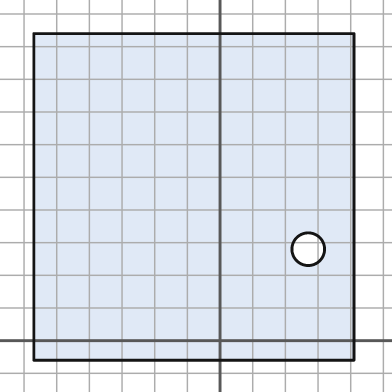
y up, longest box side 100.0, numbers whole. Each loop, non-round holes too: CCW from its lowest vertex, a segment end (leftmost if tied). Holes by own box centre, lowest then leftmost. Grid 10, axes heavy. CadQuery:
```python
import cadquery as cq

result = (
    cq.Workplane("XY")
    .moveTo(-57.0, -6.0)
    .lineTo(41.0, -6.0)
    .lineTo(41.0, 94.0)
    .lineTo(-57.0, 94.0)
    .close()
    .moveTo(27.0, 28.0)
    .circle(5.0)
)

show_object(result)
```